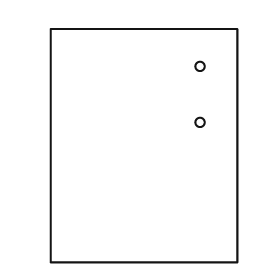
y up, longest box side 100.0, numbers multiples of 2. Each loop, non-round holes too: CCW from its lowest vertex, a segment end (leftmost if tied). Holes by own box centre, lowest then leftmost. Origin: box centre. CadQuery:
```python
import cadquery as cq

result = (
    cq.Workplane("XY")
    .moveTo(-40.0, -50.0)
    .lineTo(40.0, -50.0)
    .lineTo(40.0, 50.0)
    .lineTo(-40.0, 50.0)
    .close()
    .moveTo(24.0, 10.0)
    .circle(2.0)
    .moveTo(24.0, 34.0)
    .circle(2.0)
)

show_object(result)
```